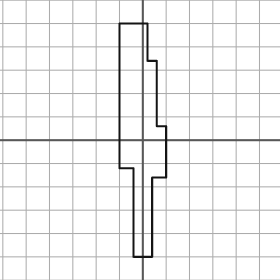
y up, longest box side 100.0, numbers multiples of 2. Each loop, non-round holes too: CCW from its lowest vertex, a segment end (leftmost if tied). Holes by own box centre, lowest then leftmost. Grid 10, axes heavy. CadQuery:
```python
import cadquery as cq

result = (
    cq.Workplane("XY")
    .moveTo(-4.0, -50.0)
    .lineTo(4.0, -50.0)
    .lineTo(4.0, -16.0)
    .lineTo(10.0, -16.0)
    .lineTo(10.0, 6.0)
    .lineTo(6.0, 6.0)
    .lineTo(6.0, 34.0)
    .lineTo(2.0, 34.0)
    .lineTo(2.0, 50.0)
    .lineTo(-10.0, 50.0)
    .lineTo(-10.0, -12.0)
    .lineTo(-4.0, -12.0)
    .close()
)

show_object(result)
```